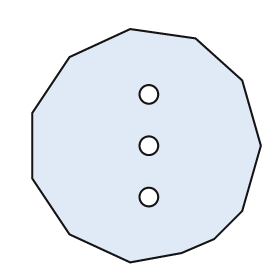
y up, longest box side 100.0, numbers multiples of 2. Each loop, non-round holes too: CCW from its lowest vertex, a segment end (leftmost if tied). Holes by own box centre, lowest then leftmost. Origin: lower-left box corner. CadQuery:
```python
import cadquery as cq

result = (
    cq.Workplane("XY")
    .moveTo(42.0, 0.0)
    .lineTo(64.0, 4.0)
    .lineTo(78.0, 10.0)
    .lineTo(90.0, 22.0)
    .lineTo(98.0, 50.0)
    .lineTo(90.0, 78.0)
    .lineTo(70.0, 96.0)
    .lineTo(42.0, 100.0)
    .lineTo(16.0, 88.0)
    .lineTo(0.0, 64.0)
    .lineTo(0.0, 36.0)
    .lineTo(16.0, 12.0)
    .close()
    .moveTo(50.0, 28.0)
    .circle(4.0)
    .moveTo(50.0, 50.0)
    .circle(4.0)
    .moveTo(50.0, 72.0)
    .circle(4.0)
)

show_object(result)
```